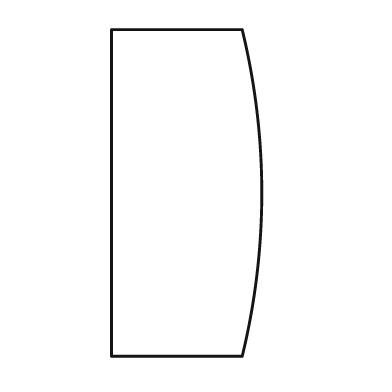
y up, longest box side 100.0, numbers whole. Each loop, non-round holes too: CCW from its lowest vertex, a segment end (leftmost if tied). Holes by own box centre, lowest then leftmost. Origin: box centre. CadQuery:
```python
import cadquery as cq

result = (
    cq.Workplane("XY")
    .moveTo(-23.0, -50.0)
    .lineTo(17.0, -50.0)
    .threePointArc((23.0, 0.0), (17.0, 50.0))
    .lineTo(-23.0, 50.0)
    .close()
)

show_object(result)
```